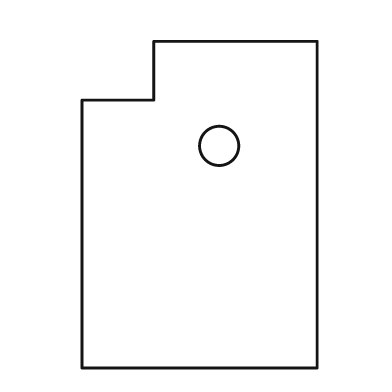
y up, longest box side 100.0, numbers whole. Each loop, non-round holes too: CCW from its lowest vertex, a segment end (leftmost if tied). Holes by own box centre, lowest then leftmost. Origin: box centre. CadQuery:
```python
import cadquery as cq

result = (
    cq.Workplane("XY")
    .moveTo(-36.0, -50.0)
    .lineTo(36.0, -50.0)
    .lineTo(36.0, 50.0)
    .lineTo(-14.0, 50.0)
    .lineTo(-14.0, 32.0)
    .lineTo(-36.0, 32.0)
    .close()
    .moveTo(6.0, 18.0)
    .circle(6.0)
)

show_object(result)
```